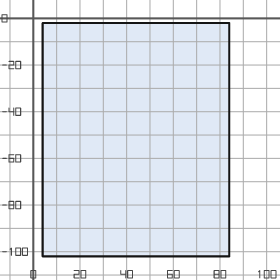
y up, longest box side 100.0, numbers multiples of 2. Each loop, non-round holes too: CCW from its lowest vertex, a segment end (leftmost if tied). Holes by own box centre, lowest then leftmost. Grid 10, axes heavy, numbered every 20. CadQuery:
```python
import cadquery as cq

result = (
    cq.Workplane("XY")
    .moveTo(4.0, -102.0)
    .lineTo(84.0, -102.0)
    .lineTo(84.0, -2.0)
    .lineTo(4.0, -2.0)
    .close()
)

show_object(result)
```